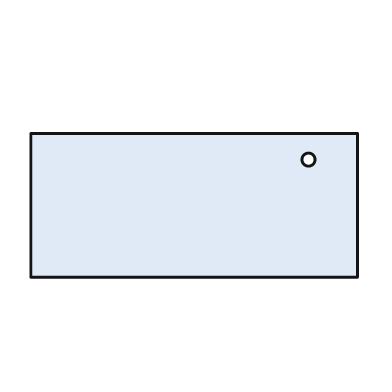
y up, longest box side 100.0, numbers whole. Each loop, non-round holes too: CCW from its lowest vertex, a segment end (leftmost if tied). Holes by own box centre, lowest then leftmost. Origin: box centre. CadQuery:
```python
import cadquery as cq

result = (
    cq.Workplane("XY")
    .moveTo(-50.0, -22.0)
    .lineTo(50.0, -22.0)
    .lineTo(50.0, 22.0)
    .lineTo(-50.0, 22.0)
    .close()
    .moveTo(35.0, 14.0)
    .circle(2.0)
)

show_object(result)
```